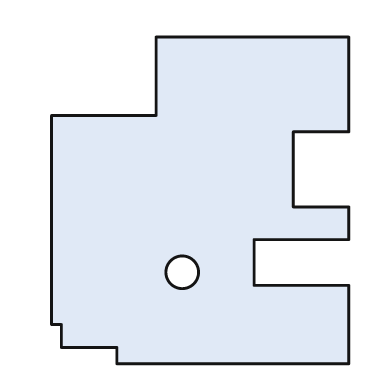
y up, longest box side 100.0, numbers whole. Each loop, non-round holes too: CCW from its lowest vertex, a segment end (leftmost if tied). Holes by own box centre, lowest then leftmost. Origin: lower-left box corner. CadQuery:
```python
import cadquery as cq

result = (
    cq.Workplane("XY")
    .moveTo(20.0, 0.0)
    .lineTo(91.0, 0.0)
    .lineTo(91.0, 24.0)
    .lineTo(62.0, 24.0)
    .lineTo(62.0, 38.0)
    .lineTo(91.0, 38.0)
    .lineTo(91.0, 48.0)
    .lineTo(74.0, 48.0)
    .lineTo(74.0, 71.0)
    .lineTo(91.0, 71.0)
    .lineTo(91.0, 100.0)
    .lineTo(32.0, 100.0)
    .lineTo(32.0, 76.0)
    .lineTo(0.0, 76.0)
    .lineTo(0.0, 12.0)
    .lineTo(3.0, 12.0)
    .lineTo(3.0, 5.0)
    .lineTo(20.0, 5.0)
    .close()
    .moveTo(40.0, 28.0)
    .circle(5.0)
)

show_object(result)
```